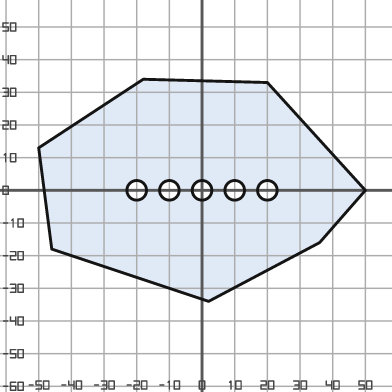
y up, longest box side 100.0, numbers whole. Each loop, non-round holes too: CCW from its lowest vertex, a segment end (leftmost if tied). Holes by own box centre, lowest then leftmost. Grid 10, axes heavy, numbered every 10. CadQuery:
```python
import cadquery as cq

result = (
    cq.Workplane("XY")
    .moveTo(2.0, -34.0)
    .lineTo(36.0, -16.0)
    .lineTo(50.0, 0.0)
    .lineTo(20.0, 33.0)
    .lineTo(-18.0, 34.0)
    .lineTo(-50.0, 13.0)
    .lineTo(-46.0, -18.0)
    .close()
    .moveTo(-20.0, 0.0)
    .circle(3.0)
    .moveTo(-10.0, 0.0)
    .circle(3.0)
    .moveTo(0.0, 0.0)
    .circle(3.0)
    .moveTo(10.0, 0.0)
    .circle(3.0)
    .moveTo(20.0, 0.0)
    .circle(3.0)
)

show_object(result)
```